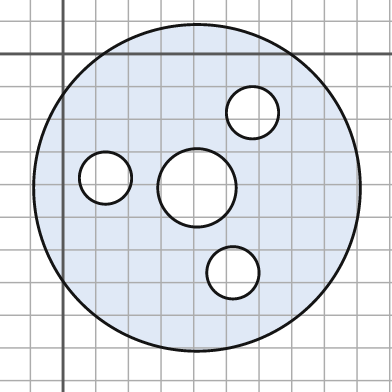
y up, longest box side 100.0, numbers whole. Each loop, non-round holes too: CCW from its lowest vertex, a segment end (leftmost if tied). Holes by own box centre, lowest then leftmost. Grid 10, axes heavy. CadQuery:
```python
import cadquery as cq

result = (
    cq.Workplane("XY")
    .moveTo(41.0, -41.0)
    .circle(50.0)
    .moveTo(52.0, -67.0)
    .circle(8.0)
    .moveTo(41.0, -41.0)
    .circle(12.0)
    .moveTo(13.0, -38.0)
    .circle(8.0)
    .moveTo(58.0, -18.0)
    .circle(8.0)
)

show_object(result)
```